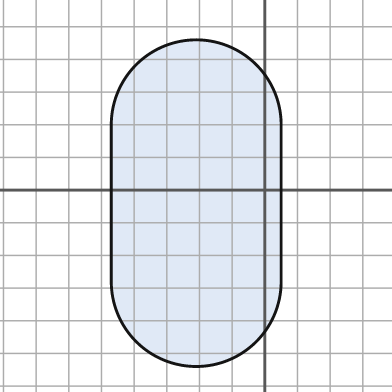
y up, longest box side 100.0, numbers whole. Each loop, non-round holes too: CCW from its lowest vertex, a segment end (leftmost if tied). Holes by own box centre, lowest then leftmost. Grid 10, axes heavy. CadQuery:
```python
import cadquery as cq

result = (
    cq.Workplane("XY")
    .moveTo(-47.0, -28.0)
    .threePointArc((-21.0, -54.0), (5.0, -28.0))
    .lineTo(5.0, 20.0)
    .threePointArc((-21.0, 46.0), (-47.0, 20.0))
    .close()
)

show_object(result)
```